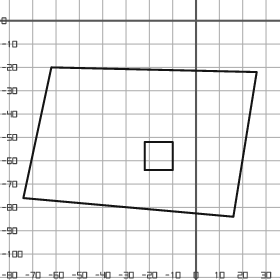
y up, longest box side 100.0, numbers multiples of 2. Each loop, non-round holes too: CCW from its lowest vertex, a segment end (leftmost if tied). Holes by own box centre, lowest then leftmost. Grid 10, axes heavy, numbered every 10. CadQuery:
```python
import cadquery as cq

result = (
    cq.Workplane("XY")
    .moveTo(16.0, -84.0)
    .lineTo(26.0, -22.0)
    .lineTo(-62.0, -20.0)
    .lineTo(-74.0, -76.0)
    .close()
    .moveTo(-22.0, -64.0)
    .lineTo(-10.0, -64.0)
    .lineTo(-10.0, -52.0)
    .lineTo(-22.0, -52.0)
    .close()
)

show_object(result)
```